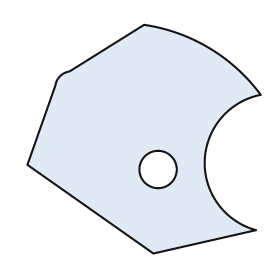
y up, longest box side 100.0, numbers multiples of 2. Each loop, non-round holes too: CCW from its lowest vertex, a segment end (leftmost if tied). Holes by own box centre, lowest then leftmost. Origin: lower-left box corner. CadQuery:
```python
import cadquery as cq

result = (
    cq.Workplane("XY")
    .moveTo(54.0, 0.0)
    .lineTo(98.0, 10.0)
    .threePointArc((76.0, 40.0), (100.0, 68.0))
    .threePointArc((78.0, 88.0), (50.0, 98.0))
    .lineTo(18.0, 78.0)
    .threePointArc((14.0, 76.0), (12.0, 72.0))
    .lineTo(0.0, 38.0)
    .close()
    .moveTo(56.0, 36.0)
    .circle(8.0)
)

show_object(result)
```